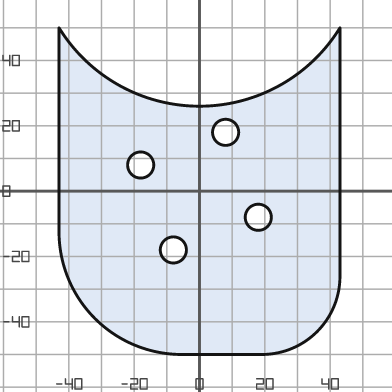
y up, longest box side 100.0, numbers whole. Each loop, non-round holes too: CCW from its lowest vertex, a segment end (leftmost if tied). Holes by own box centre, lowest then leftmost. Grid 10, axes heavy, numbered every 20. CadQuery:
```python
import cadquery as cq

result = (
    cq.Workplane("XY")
    .moveTo(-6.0, -50.0)
    .lineTo(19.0, -50.0)
    .threePointArc((36.0, -43.0), (43.0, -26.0))
    .lineTo(43.0, 50.0)
    .threePointArc((0.0, 26.0), (-43.0, 50.0))
    .lineTo(-43.0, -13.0)
    .threePointArc((-32.0, -39.0), (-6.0, -50.0))
    .close()
    .moveTo(-8.0, -18.0)
    .circle(4.0)
    .moveTo(18.0, -8.0)
    .circle(4.0)
    .moveTo(-18.0, 8.0)
    .circle(4.0)
    .moveTo(8.0, 18.0)
    .circle(4.0)
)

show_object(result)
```